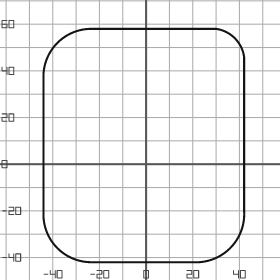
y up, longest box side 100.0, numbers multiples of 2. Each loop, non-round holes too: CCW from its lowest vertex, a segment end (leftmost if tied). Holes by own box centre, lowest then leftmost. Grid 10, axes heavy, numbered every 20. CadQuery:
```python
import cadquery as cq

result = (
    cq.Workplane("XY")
    .moveTo(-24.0, -42.0)
    .lineTo(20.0, -42.0)
    .threePointArc((36.0, -36.0), (42.0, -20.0))
    .lineTo(42.0, 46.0)
    .threePointArc((38.0, 54.0), (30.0, 58.0))
    .lineTo(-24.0, 58.0)
    .threePointArc((-38.0, 52.0), (-44.0, 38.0))
    .lineTo(-44.0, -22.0)
    .threePointArc((-38.0, -36.0), (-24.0, -42.0))
    .close()
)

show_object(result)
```